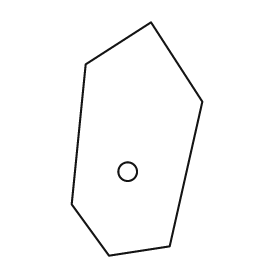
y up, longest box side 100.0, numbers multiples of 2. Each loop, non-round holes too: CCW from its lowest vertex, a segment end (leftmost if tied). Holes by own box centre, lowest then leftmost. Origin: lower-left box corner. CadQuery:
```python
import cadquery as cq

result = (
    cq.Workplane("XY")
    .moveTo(16.0, 0.0)
    .lineTo(42.0, 4.0)
    .lineTo(56.0, 66.0)
    .lineTo(34.0, 100.0)
    .lineTo(6.0, 82.0)
    .lineTo(0.0, 22.0)
    .close()
    .moveTo(24.0, 36.0)
    .circle(4.0)
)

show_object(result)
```